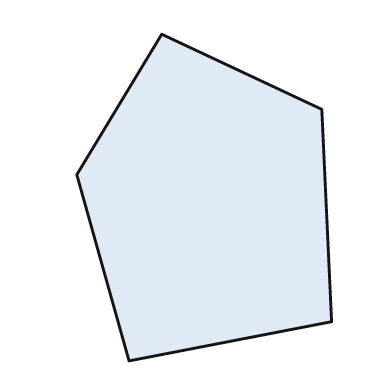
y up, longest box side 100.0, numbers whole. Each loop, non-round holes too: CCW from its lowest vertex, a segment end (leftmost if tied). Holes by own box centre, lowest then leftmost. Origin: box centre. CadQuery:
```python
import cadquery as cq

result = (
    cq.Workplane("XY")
    .moveTo(-23.0, -50.0)
    .lineTo(39.0, -38.0)
    .lineTo(36.0, 27.0)
    .lineTo(-13.0, 50.0)
    .lineTo(-39.0, 7.0)
    .close()
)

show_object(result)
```